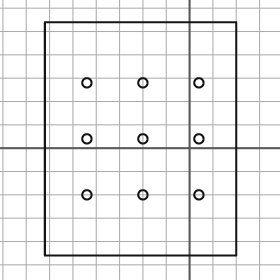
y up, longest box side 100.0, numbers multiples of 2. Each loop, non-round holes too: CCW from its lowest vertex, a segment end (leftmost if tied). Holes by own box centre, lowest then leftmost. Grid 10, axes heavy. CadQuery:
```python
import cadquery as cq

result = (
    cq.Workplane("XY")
    .moveTo(-62.0, -46.0)
    .lineTo(20.0, -46.0)
    .lineTo(20.0, 54.0)
    .lineTo(-62.0, 54.0)
    .close()
    .moveTo(-44.0, -20.0)
    .circle(2.0)
    .moveTo(-20.0, -20.0)
    .circle(2.0)
    .moveTo(4.0, -20.0)
    .circle(2.0)
    .moveTo(-44.0, 4.0)
    .circle(2.0)
    .moveTo(-20.0, 4.0)
    .circle(2.0)
    .moveTo(4.0, 4.0)
    .circle(2.0)
    .moveTo(-44.0, 28.0)
    .circle(2.0)
    .moveTo(-20.0, 28.0)
    .circle(2.0)
    .moveTo(4.0, 28.0)
    .circle(2.0)
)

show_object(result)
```